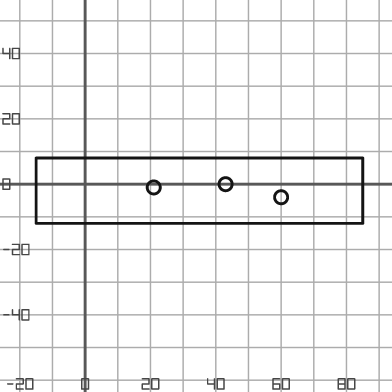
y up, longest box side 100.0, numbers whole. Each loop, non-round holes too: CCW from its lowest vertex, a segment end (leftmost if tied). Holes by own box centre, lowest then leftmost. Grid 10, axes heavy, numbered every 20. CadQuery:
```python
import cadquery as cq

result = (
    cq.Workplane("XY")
    .moveTo(-15.0, -12.0)
    .lineTo(85.0, -12.0)
    .lineTo(85.0, 8.0)
    .lineTo(-15.0, 8.0)
    .close()
    .moveTo(60.0, -4.0)
    .circle(2.0)
    .moveTo(21.0, -1.0)
    .circle(2.0)
    .moveTo(43.0, 0.0)
    .circle(2.0)
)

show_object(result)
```